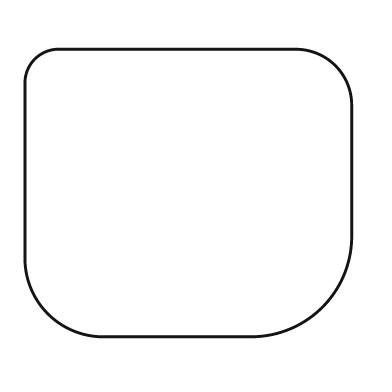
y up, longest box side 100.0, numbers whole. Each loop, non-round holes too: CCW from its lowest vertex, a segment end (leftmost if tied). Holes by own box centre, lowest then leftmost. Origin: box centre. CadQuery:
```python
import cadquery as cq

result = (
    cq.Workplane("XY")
    .moveTo(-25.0, -44.0)
    .lineTo(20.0, -44.0)
    .threePointArc((41.0, -35.0), (50.0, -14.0))
    .lineTo(50.0, 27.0)
    .threePointArc((45.0, 39.0), (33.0, 44.0))
    .lineTo(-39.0, 44.0)
    .threePointArc((-47.0, 41.0), (-50.0, 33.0))
    .lineTo(-50.0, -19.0)
    .threePointArc((-43.0, -37.0), (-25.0, -44.0))
    .close()
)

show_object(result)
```